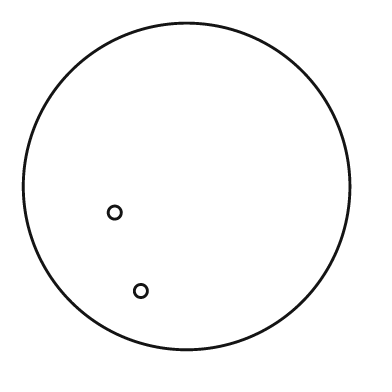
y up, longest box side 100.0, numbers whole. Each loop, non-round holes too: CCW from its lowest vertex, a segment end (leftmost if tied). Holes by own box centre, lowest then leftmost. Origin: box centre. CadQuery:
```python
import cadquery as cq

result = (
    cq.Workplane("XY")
    .moveTo(0.0, 0.0)
    .circle(50.0)
    .moveTo(-14.0, -32.0)
    .circle(2.0)
    .moveTo(-22.0, -8.0)
    .circle(2.0)
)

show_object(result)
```